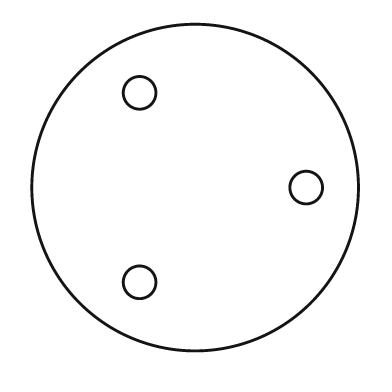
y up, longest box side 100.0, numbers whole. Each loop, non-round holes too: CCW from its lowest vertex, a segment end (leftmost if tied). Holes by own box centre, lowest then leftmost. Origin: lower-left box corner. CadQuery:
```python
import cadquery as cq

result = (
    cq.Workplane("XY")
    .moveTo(50.0, 50.0)
    .circle(50.0)
    .moveTo(33.0, 21.0)
    .circle(5.0)
    .moveTo(84.0, 50.0)
    .circle(5.0)
    .moveTo(33.0, 79.0)
    .circle(5.0)
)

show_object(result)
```